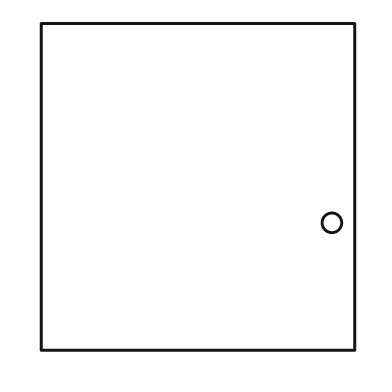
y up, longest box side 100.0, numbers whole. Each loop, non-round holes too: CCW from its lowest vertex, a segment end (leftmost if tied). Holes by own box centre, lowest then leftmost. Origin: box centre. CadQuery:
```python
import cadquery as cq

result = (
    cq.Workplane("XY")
    .moveTo(-48.0, -50.0)
    .lineTo(48.0, -50.0)
    .lineTo(48.0, 50.0)
    .lineTo(-48.0, 50.0)
    .close()
    .moveTo(41.0, -11.0)
    .circle(3.0)
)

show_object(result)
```